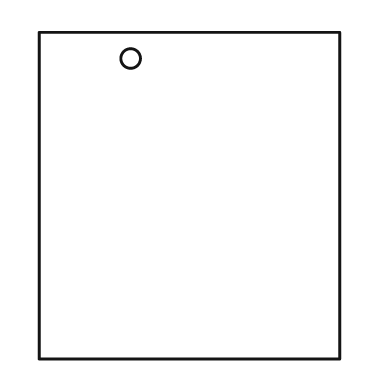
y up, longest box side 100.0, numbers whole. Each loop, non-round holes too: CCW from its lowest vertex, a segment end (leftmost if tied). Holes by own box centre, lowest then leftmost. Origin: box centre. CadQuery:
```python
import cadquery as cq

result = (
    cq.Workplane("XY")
    .moveTo(-46.0, -50.0)
    .lineTo(46.0, -50.0)
    .lineTo(46.0, 50.0)
    .lineTo(-46.0, 50.0)
    .close()
    .moveTo(-18.0, 42.0)
    .circle(3.0)
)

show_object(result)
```